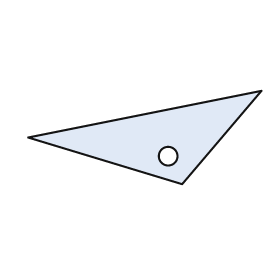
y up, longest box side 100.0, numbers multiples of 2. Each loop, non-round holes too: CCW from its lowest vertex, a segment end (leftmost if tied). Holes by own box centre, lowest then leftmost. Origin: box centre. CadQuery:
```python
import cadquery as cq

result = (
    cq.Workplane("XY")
    .moveTo(16.0, -20.0)
    .lineTo(50.0, 20.0)
    .lineTo(-50.0, 0.0)
    .close()
    .moveTo(10.0, -8.0)
    .circle(4.0)
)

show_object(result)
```